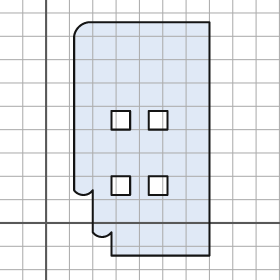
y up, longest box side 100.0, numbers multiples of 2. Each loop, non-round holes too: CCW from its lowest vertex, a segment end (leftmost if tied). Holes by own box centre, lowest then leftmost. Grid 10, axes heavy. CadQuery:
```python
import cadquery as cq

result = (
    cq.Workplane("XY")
    .moveTo(28.0, -14.0)
    .lineTo(70.0, -14.0)
    .lineTo(70.0, 86.0)
    .lineTo(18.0, 86.0)
    .threePointArc((14.0, 84.0), (12.0, 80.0))
    .lineTo(12.0, 14.0)
    .threePointArc((16.0, 12.0), (20.0, 14.0))
    .lineTo(20.0, -4.0)
    .threePointArc((24.0, -6.0), (28.0, -4.0))
    .close()
    .moveTo(28.0, 12.0)
    .lineTo(36.0, 12.0)
    .lineTo(36.0, 20.0)
    .lineTo(28.0, 20.0)
    .close()
    .moveTo(44.0, 12.0)
    .lineTo(52.0, 12.0)
    .lineTo(52.0, 20.0)
    .lineTo(44.0, 20.0)
    .close()
    .moveTo(28.0, 40.0)
    .lineTo(36.0, 40.0)
    .lineTo(36.0, 48.0)
    .lineTo(28.0, 48.0)
    .close()
    .moveTo(44.0, 40.0)
    .lineTo(52.0, 40.0)
    .lineTo(52.0, 48.0)
    .lineTo(44.0, 48.0)
    .close()
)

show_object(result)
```